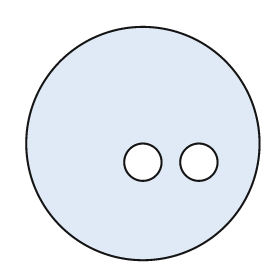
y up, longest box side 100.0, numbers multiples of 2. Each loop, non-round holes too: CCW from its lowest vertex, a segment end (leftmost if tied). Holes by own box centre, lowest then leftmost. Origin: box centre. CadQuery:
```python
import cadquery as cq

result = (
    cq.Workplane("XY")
    .moveTo(0.0, 0.0)
    .circle(50.0)
    .moveTo(0.0, -8.0)
    .circle(8.0)
    .moveTo(24.0, -8.0)
    .circle(8.0)
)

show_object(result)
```